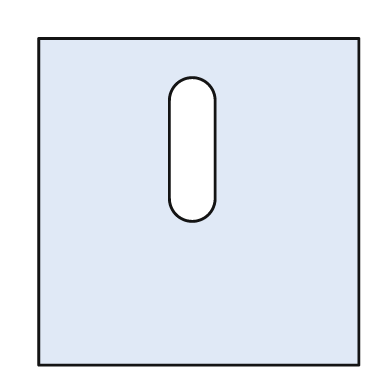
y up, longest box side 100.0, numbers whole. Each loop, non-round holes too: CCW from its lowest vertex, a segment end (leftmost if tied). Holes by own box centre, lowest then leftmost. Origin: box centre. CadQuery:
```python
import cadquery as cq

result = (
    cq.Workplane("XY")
    .moveTo(-49.0, -50.0)
    .lineTo(49.0, -50.0)
    .lineTo(49.0, 50.0)
    .lineTo(-49.0, 50.0)
    .close()
    .moveTo(-9.0, 1.0)
    .threePointArc((-2.0, -6.0), (5.0, 1.0))
    .lineTo(5.0, 31.0)
    .threePointArc((-2.0, 38.0), (-9.0, 31.0))
    .close()
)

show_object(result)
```